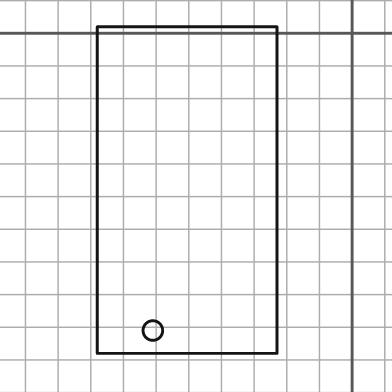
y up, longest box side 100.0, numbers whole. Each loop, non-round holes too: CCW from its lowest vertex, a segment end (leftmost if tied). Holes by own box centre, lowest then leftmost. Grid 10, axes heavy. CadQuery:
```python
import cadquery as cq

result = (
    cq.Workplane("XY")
    .moveTo(-78.0, -98.0)
    .lineTo(-23.0, -98.0)
    .lineTo(-23.0, 2.0)
    .lineTo(-78.0, 2.0)
    .close()
    .moveTo(-61.0, -91.0)
    .circle(3.0)
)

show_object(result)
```